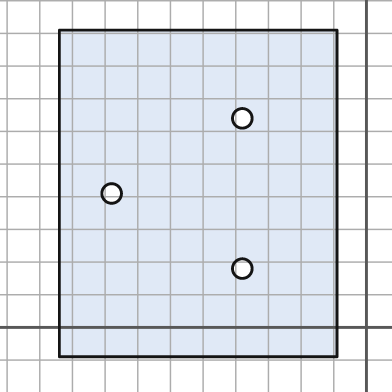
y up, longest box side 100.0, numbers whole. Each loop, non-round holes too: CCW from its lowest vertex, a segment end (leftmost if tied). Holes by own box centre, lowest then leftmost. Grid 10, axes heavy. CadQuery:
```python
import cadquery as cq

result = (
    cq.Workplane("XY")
    .moveTo(-94.0, -9.0)
    .lineTo(-9.0, -9.0)
    .lineTo(-9.0, 91.0)
    .lineTo(-94.0, 91.0)
    .close()
    .moveTo(-38.0, 18.0)
    .circle(3.0)
    .moveTo(-78.0, 41.0)
    .circle(3.0)
    .moveTo(-38.0, 64.0)
    .circle(3.0)
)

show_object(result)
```